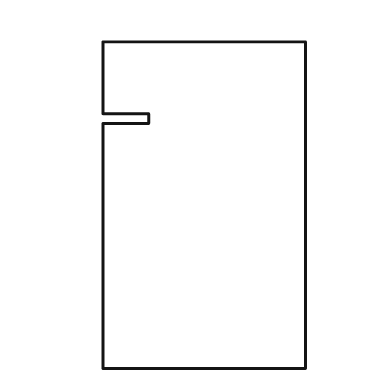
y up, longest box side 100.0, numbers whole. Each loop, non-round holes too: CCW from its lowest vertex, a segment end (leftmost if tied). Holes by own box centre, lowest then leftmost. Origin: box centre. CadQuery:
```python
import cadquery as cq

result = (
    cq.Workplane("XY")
    .moveTo(-31.0, -50.0)
    .lineTo(31.0, -50.0)
    .lineTo(31.0, 50.0)
    .lineTo(-31.0, 50.0)
    .lineTo(-31.0, 28.0)
    .lineTo(-17.0, 28.0)
    .lineTo(-17.0, 25.0)
    .lineTo(-31.0, 25.0)
    .close()
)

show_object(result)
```